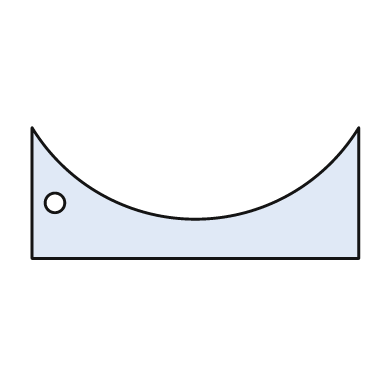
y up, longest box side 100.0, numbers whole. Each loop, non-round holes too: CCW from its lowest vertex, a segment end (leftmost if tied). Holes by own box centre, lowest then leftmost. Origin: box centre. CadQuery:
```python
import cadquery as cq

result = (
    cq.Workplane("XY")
    .moveTo(-50.0, -20.0)
    .lineTo(50.0, -20.0)
    .lineTo(50.0, 20.0)
    .threePointArc((0.0, -8.0), (-50.0, 20.0))
    .close()
    .moveTo(-43.0, -3.0)
    .circle(3.0)
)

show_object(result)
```